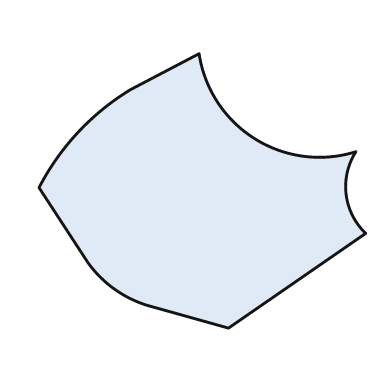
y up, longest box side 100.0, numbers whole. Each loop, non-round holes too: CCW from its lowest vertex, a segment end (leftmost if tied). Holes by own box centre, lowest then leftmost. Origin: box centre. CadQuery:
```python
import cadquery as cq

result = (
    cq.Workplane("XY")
    .moveTo(8.0, -42.0)
    .lineTo(50.0, -13.0)
    .threePointArc((44.0, -1.0), (47.0, 12.0))
    .threePointArc((16.0, 16.0), (-1.0, 42.0))
    .lineTo(-22.0, 31.0)
    .threePointArc((-38.0, 18.0), (-50.0, 1.0))
    .lineTo(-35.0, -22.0)
    .threePointArc((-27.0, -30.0), (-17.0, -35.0))
    .close()
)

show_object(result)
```